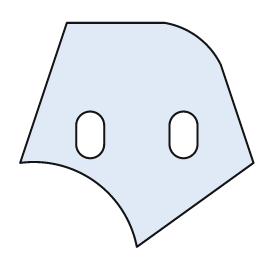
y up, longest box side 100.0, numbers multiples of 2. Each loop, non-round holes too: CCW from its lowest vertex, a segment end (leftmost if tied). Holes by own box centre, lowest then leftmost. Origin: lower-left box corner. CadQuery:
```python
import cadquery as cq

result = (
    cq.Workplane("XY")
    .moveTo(50.0, 0.0)
    .lineTo(100.0, 36.0)
    .lineTo(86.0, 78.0)
    .threePointArc((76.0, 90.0), (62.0, 96.0))
    .lineTo(20.0, 96.0)
    .lineTo(0.0, 36.0)
    .threePointArc((32.0, 28.0), (50.0, 0.0))
    .close()
    .moveTo(24.0, 44.0)
    .threePointArc((30.0, 38.0), (36.0, 44.0))
    .lineTo(36.0, 52.0)
    .threePointArc((30.0, 58.0), (24.0, 52.0))
    .close()
    .moveTo(64.0, 44.0)
    .threePointArc((70.0, 38.0), (76.0, 44.0))
    .lineTo(76.0, 52.0)
    .threePointArc((70.0, 58.0), (64.0, 52.0))
    .close()
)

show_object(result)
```